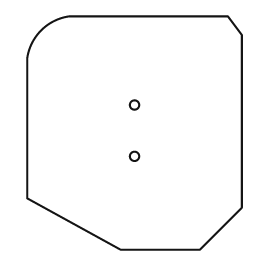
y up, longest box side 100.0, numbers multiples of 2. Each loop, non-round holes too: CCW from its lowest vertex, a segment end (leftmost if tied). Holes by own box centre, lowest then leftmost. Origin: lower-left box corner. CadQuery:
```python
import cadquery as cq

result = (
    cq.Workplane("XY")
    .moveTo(40.0, 0.0)
    .lineTo(74.0, 0.0)
    .lineTo(92.0, 18.0)
    .lineTo(92.0, 92.0)
    .lineTo(86.0, 100.0)
    .lineTo(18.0, 100.0)
    .threePointArc((6.0, 94.0), (0.0, 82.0))
    .lineTo(0.0, 22.0)
    .close()
    .moveTo(46.0, 40.0)
    .circle(2.0)
    .moveTo(46.0, 62.0)
    .circle(2.0)
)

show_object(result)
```